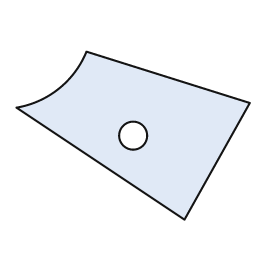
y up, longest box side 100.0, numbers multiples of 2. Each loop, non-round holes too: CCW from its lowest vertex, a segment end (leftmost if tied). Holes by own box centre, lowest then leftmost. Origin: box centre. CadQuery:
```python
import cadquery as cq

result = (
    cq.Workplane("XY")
    .moveTo(22.0, -36.0)
    .lineTo(50.0, 14.0)
    .lineTo(-20.0, 36.0)
    .threePointArc((-32.0, 20.0), (-50.0, 12.0))
    .close()
    .moveTo(0.0, 0.0)
    .circle(6.0)
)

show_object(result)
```